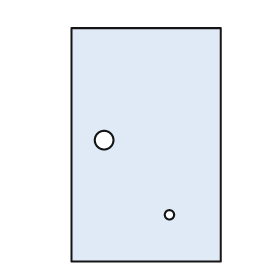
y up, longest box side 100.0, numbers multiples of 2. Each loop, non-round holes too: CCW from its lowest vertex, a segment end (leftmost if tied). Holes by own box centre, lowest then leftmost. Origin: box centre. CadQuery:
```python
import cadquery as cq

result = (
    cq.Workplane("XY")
    .moveTo(-32.0, -50.0)
    .lineTo(32.0, -50.0)
    .lineTo(32.0, 50.0)
    .lineTo(-32.0, 50.0)
    .close()
    .moveTo(10.0, -30.0)
    .circle(2.0)
    .moveTo(-18.0, 2.0)
    .circle(4.0)
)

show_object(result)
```